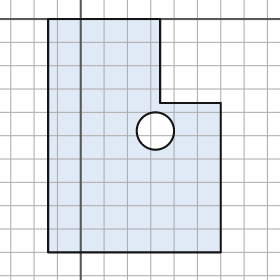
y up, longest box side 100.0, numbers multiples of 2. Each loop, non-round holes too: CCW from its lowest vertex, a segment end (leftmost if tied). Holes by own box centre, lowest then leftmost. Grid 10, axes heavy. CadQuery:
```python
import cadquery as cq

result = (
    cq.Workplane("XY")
    .moveTo(-14.0, -100.0)
    .lineTo(60.0, -100.0)
    .lineTo(60.0, -36.0)
    .lineTo(34.0, -36.0)
    .lineTo(34.0, 0.0)
    .lineTo(-14.0, 0.0)
    .close()
    .moveTo(32.0, -48.0)
    .circle(8.0)
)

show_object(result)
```